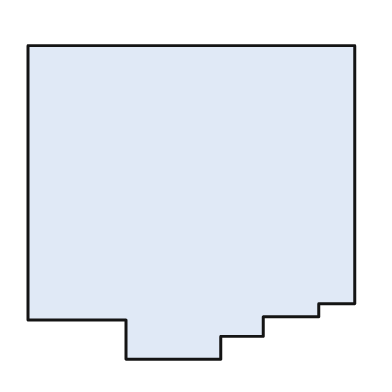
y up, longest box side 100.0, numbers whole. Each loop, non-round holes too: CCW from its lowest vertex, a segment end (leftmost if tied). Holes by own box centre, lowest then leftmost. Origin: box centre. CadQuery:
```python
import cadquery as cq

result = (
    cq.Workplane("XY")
    .moveTo(-20.0, -48.0)
    .lineTo(9.0, -48.0)
    .lineTo(9.0, -41.0)
    .lineTo(22.0, -41.0)
    .lineTo(22.0, -35.0)
    .lineTo(39.0, -35.0)
    .lineTo(39.0, -31.0)
    .lineTo(50.0, -31.0)
    .lineTo(50.0, 48.0)
    .lineTo(-50.0, 48.0)
    .lineTo(-50.0, -36.0)
    .lineTo(-20.0, -36.0)
    .close()
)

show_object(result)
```